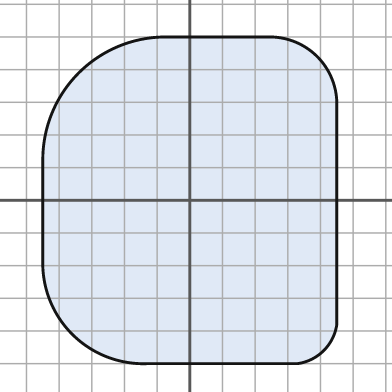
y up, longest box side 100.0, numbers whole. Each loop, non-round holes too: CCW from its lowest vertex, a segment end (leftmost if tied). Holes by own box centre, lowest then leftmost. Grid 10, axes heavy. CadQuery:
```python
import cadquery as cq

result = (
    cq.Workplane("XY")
    .moveTo(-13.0, -50.0)
    .lineTo(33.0, -50.0)
    .threePointArc((41.0, -46.0), (45.0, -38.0))
    .lineTo(45.0, 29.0)
    .threePointArc((39.0, 44.0), (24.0, 50.0))
    .lineTo(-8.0, 50.0)
    .threePointArc((-34.0, 39.0), (-45.0, 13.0))
    .lineTo(-45.0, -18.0)
    .threePointArc((-36.0, -41.0), (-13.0, -50.0))
    .close()
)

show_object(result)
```